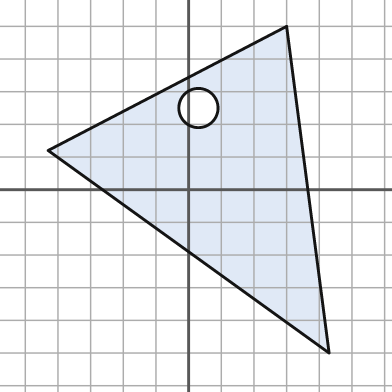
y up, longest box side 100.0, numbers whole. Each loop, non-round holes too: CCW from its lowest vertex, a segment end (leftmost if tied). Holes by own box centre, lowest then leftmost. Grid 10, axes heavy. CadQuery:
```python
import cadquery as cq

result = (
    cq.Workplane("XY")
    .moveTo(43.0, -50.0)
    .lineTo(30.0, 50.0)
    .lineTo(-43.0, 12.0)
    .close()
    .moveTo(3.0, 25.0)
    .circle(6.0)
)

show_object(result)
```